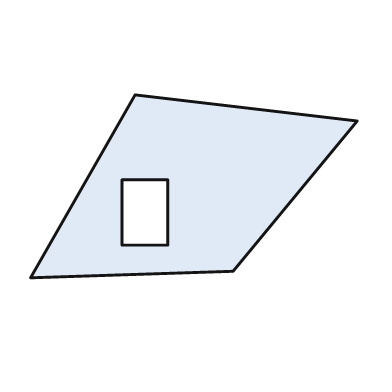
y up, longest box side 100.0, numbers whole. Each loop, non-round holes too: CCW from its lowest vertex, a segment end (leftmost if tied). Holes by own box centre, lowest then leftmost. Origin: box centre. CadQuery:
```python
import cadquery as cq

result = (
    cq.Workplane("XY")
    .moveTo(-50.0, -28.0)
    .lineTo(12.0, -26.0)
    .lineTo(50.0, 20.0)
    .lineTo(-18.0, 28.0)
    .close()
    .moveTo(-22.0, -18.0)
    .lineTo(-8.0, -18.0)
    .lineTo(-8.0, 2.0)
    .lineTo(-22.0, 2.0)
    .close()
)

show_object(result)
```